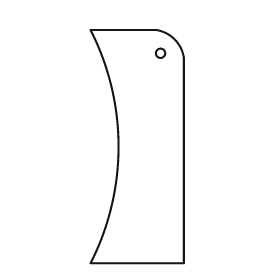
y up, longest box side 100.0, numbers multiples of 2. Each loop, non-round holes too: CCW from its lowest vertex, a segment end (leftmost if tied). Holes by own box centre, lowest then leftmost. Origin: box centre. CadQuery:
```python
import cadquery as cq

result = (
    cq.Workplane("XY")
    .moveTo(-20.0, -50.0)
    .lineTo(20.0, -50.0)
    .lineTo(20.0, 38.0)
    .threePointArc((16.0, 46.0), (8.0, 50.0))
    .lineTo(-20.0, 50.0)
    .threePointArc((-8.0, 0.0), (-20.0, -50.0))
    .close()
    .moveTo(10.0, 40.0)
    .circle(2.0)
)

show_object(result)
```